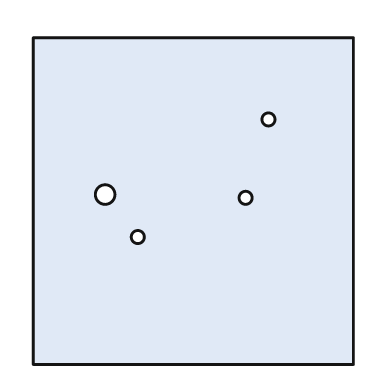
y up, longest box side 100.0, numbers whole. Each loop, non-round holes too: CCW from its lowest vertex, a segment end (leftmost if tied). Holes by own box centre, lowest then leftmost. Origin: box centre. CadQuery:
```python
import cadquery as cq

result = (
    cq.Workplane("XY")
    .moveTo(-49.0, -50.0)
    .lineTo(49.0, -50.0)
    .lineTo(49.0, 50.0)
    .lineTo(-49.0, 50.0)
    .close()
    .moveTo(-17.0, -11.0)
    .circle(2.0)
    .moveTo(16.0, 1.0)
    .circle(2.0)
    .moveTo(-27.0, 2.0)
    .circle(3.0)
    .moveTo(23.0, 25.0)
    .circle(2.0)
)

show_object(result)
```